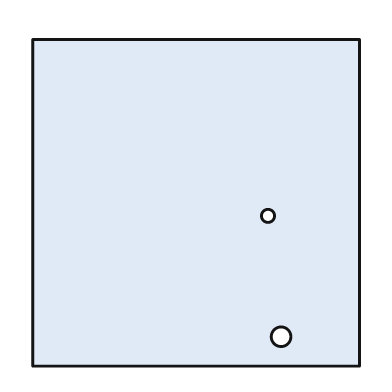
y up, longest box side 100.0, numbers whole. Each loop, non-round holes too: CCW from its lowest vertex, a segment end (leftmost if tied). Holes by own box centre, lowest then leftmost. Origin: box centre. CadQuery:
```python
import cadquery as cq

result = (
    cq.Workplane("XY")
    .moveTo(-50.0, -50.0)
    .lineTo(50.0, -50.0)
    .lineTo(50.0, 50.0)
    .lineTo(-50.0, 50.0)
    .close()
    .moveTo(26.0, -41.0)
    .circle(3.0)
    .moveTo(22.0, -4.0)
    .circle(2.0)
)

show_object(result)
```